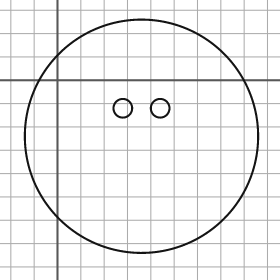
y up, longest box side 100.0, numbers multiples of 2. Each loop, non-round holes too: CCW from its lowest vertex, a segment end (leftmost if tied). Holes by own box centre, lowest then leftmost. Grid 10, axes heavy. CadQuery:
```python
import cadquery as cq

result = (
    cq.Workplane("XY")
    .moveTo(36.0, -24.0)
    .circle(50.0)
    .moveTo(28.0, -12.0)
    .circle(4.0)
    .moveTo(44.0, -12.0)
    .circle(4.0)
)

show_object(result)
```